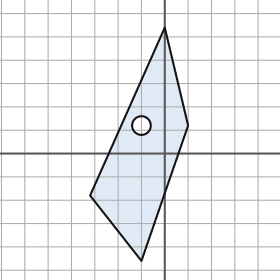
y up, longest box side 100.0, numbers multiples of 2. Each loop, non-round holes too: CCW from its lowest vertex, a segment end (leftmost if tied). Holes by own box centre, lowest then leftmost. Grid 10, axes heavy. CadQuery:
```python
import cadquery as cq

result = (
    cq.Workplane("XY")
    .moveTo(-10.0, -46.0)
    .lineTo(10.0, 12.0)
    .lineTo(0.0, 54.0)
    .lineTo(-32.0, -18.0)
    .close()
    .moveTo(-10.0, 12.0)
    .circle(4.0)
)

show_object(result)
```